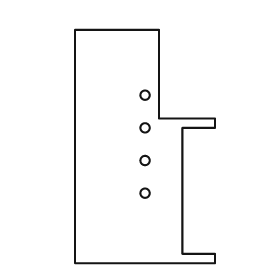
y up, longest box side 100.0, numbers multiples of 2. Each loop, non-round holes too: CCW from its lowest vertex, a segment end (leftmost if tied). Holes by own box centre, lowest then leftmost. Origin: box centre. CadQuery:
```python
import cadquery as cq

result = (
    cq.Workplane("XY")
    .moveTo(-30.0, -50.0)
    .lineTo(30.0, -50.0)
    .lineTo(30.0, -46.0)
    .lineTo(16.0, -46.0)
    .lineTo(16.0, 8.0)
    .lineTo(30.0, 8.0)
    .lineTo(30.0, 12.0)
    .lineTo(6.0, 12.0)
    .lineTo(6.0, 50.0)
    .lineTo(-30.0, 50.0)
    .close()
    .moveTo(0.0, -20.0)
    .circle(2.0)
    .moveTo(0.0, -6.0)
    .circle(2.0)
    .moveTo(0.0, 8.0)
    .circle(2.0)
    .moveTo(0.0, 22.0)
    .circle(2.0)
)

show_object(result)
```